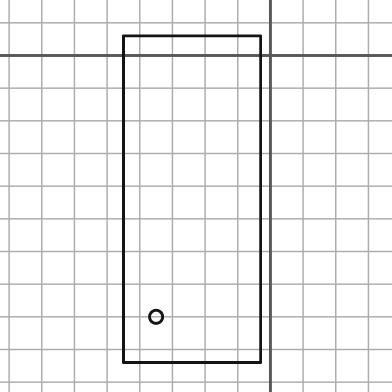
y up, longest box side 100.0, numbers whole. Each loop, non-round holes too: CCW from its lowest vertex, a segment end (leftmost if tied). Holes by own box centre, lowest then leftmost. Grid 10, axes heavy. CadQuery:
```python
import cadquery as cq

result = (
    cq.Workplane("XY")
    .moveTo(-45.0, -94.0)
    .lineTo(-3.0, -94.0)
    .lineTo(-3.0, 6.0)
    .lineTo(-45.0, 6.0)
    .close()
    .moveTo(-35.0, -80.0)
    .circle(2.0)
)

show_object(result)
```